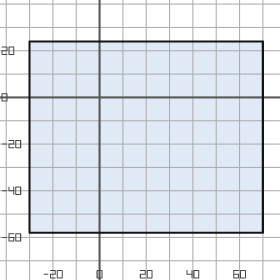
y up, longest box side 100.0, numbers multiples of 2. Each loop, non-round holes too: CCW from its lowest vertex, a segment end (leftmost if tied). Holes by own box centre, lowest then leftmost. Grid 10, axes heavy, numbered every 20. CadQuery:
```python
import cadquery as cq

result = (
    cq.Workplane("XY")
    .moveTo(-30.0, -58.0)
    .lineTo(70.0, -58.0)
    .lineTo(70.0, 24.0)
    .lineTo(-30.0, 24.0)
    .close()
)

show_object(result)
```